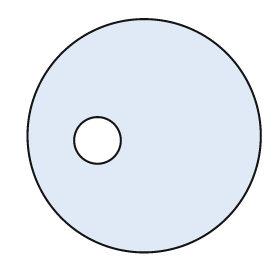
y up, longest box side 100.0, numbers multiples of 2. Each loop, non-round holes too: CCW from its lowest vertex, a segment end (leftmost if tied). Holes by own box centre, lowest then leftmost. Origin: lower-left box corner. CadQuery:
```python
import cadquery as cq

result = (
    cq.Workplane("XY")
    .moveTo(50.0, 50.0)
    .circle(50.0)
    .moveTo(30.0, 48.0)
    .circle(10.0)
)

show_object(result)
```